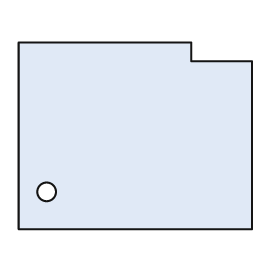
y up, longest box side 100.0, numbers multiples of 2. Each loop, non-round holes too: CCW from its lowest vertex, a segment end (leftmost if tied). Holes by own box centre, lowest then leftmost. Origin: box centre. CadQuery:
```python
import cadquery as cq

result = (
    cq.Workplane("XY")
    .moveTo(-50.0, -40.0)
    .lineTo(50.0, -40.0)
    .lineTo(50.0, 32.0)
    .lineTo(24.0, 32.0)
    .lineTo(24.0, 40.0)
    .lineTo(-50.0, 40.0)
    .close()
    .moveTo(-38.0, -24.0)
    .circle(4.0)
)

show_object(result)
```